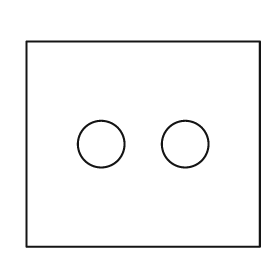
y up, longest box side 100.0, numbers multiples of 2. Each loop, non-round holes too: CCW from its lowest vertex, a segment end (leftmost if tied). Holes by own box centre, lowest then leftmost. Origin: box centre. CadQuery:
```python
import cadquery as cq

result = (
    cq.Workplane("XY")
    .moveTo(-50.0, -44.0)
    .lineTo(50.0, -44.0)
    .lineTo(50.0, 44.0)
    .lineTo(-50.0, 44.0)
    .close()
    .moveTo(-18.0, 0.0)
    .circle(10.0)
    .moveTo(18.0, 0.0)
    .circle(10.0)
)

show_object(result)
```